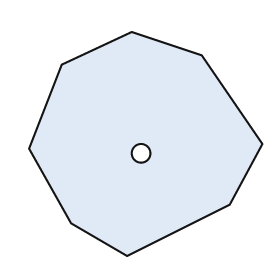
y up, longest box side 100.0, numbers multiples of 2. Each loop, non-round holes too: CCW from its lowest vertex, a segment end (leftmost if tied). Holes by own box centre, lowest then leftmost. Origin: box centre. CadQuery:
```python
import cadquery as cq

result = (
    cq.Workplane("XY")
    .moveTo(-8.0, -48.0)
    .lineTo(36.0, -26.0)
    .lineTo(50.0, 0.0)
    .lineTo(24.0, 38.0)
    .lineTo(-6.0, 48.0)
    .lineTo(-36.0, 34.0)
    .lineTo(-50.0, -2.0)
    .lineTo(-32.0, -34.0)
    .close()
    .moveTo(-2.0, -4.0)
    .circle(4.0)
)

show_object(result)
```